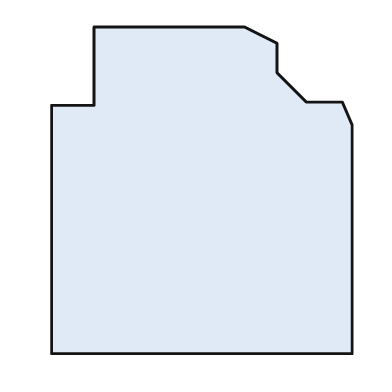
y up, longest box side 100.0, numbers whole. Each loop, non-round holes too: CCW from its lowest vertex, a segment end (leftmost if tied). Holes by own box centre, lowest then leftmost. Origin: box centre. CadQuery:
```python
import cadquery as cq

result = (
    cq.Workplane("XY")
    .moveTo(-46.0, -50.0)
    .lineTo(46.0, -50.0)
    .lineTo(46.0, 20.0)
    .lineTo(43.0, 27.0)
    .lineTo(32.0, 27.0)
    .lineTo(23.0, 36.0)
    .lineTo(23.0, 45.0)
    .lineTo(13.0, 50.0)
    .lineTo(-33.0, 50.0)
    .lineTo(-33.0, 26.0)
    .lineTo(-46.0, 26.0)
    .close()
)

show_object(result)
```